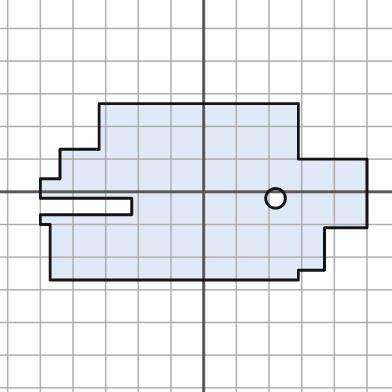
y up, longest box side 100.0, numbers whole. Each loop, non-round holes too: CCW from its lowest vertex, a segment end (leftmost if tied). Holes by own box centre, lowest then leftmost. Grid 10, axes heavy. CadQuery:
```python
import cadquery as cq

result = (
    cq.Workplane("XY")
    .moveTo(-47.0, -27.0)
    .lineTo(29.0, -27.0)
    .lineTo(29.0, -24.0)
    .lineTo(37.0, -24.0)
    .lineTo(37.0, -11.0)
    .lineTo(50.0, -11.0)
    .lineTo(50.0, 10.0)
    .lineTo(29.0, 10.0)
    .lineTo(29.0, 27.0)
    .lineTo(-32.0, 27.0)
    .lineTo(-32.0, 13.0)
    .lineTo(-44.0, 13.0)
    .lineTo(-44.0, 4.0)
    .lineTo(-50.0, 4.0)
    .lineTo(-50.0, -2.0)
    .lineTo(-22.0, -2.0)
    .lineTo(-22.0, -7.0)
    .lineTo(-50.0, -7.0)
    .lineTo(-50.0, -10.0)
    .lineTo(-47.0, -10.0)
    .close()
    .moveTo(22.0, -2.0)
    .circle(3.0)
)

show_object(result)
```